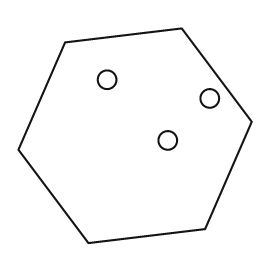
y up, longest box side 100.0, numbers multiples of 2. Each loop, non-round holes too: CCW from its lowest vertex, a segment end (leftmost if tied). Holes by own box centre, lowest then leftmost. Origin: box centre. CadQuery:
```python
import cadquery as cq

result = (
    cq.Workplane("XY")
    .moveTo(-20.0, -46.0)
    .lineTo(30.0, -40.0)
    .lineTo(50.0, 6.0)
    .lineTo(20.0, 46.0)
    .lineTo(-30.0, 40.0)
    .lineTo(-50.0, -6.0)
    .close()
    .moveTo(14.0, -2.0)
    .circle(4.0)
    .moveTo(32.0, 16.0)
    .circle(4.0)
    .moveTo(-12.0, 24.0)
    .circle(4.0)
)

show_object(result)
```